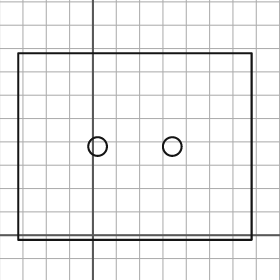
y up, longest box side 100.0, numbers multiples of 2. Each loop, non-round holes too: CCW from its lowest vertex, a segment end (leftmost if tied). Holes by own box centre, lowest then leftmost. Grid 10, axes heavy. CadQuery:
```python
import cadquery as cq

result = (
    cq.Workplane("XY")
    .moveTo(-32.0, -2.0)
    .lineTo(68.0, -2.0)
    .lineTo(68.0, 78.0)
    .lineTo(-32.0, 78.0)
    .close()
    .moveTo(2.0, 38.0)
    .circle(4.0)
    .moveTo(34.0, 38.0)
    .circle(4.0)
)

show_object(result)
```